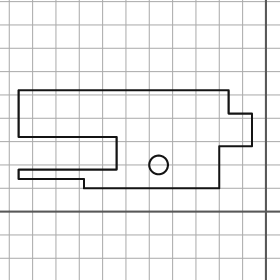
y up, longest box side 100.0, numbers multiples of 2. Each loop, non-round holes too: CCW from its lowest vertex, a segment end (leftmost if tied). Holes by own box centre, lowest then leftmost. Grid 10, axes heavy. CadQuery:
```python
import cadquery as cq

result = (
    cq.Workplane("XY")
    .moveTo(-78.0, 10.0)
    .lineTo(-20.0, 10.0)
    .lineTo(-20.0, 28.0)
    .lineTo(-6.0, 28.0)
    .lineTo(-6.0, 42.0)
    .lineTo(-16.0, 42.0)
    .lineTo(-16.0, 52.0)
    .lineTo(-106.0, 52.0)
    .lineTo(-106.0, 32.0)
    .lineTo(-64.0, 32.0)
    .lineTo(-64.0, 18.0)
    .lineTo(-106.0, 18.0)
    .lineTo(-106.0, 14.0)
    .lineTo(-78.0, 14.0)
    .close()
    .moveTo(-46.0, 20.0)
    .circle(4.0)
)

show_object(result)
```